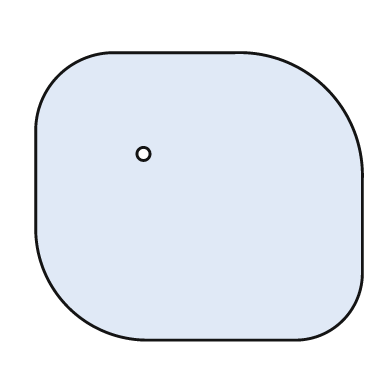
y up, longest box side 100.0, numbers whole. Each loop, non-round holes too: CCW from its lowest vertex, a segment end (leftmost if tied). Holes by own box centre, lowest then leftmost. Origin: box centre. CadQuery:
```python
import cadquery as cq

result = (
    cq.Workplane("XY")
    .moveTo(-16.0, -44.0)
    .lineTo(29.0, -44.0)
    .threePointArc((44.0, -38.0), (50.0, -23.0))
    .lineTo(50.0, 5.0)
    .threePointArc((39.0, 33.0), (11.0, 44.0))
    .lineTo(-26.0, 44.0)
    .threePointArc((-43.0, 37.0), (-50.0, 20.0))
    .lineTo(-50.0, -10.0)
    .threePointArc((-40.0, -34.0), (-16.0, -44.0))
    .close()
    .moveTo(-17.0, 13.0)
    .circle(2.0)
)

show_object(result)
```